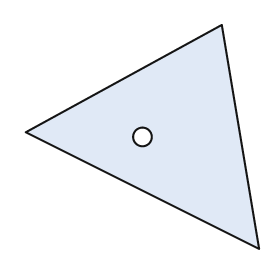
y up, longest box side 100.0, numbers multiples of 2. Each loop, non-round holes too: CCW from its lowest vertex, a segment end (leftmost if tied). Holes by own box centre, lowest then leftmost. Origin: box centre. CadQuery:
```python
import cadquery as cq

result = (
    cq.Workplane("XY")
    .moveTo(50.0, -48.0)
    .lineTo(34.0, 48.0)
    .lineTo(-50.0, 2.0)
    .close()
    .moveTo(0.0, 0.0)
    .circle(4.0)
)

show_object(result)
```